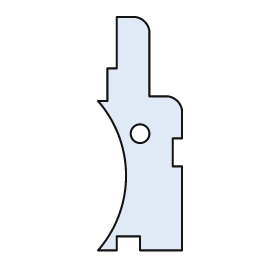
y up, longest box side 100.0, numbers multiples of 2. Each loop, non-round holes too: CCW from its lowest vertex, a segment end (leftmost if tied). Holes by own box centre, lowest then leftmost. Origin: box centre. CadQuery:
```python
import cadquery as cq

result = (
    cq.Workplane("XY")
    .moveTo(-18.0, -50.0)
    .lineTo(-10.0, -50.0)
    .lineTo(-10.0, -44.0)
    .lineTo(0.0, -44.0)
    .lineTo(0.0, -50.0)
    .lineTo(18.0, -50.0)
    .lineTo(18.0, -14.0)
    .lineTo(14.0, -14.0)
    .lineTo(14.0, -2.0)
    .lineTo(18.0, -2.0)
    .lineTo(18.0, 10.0)
    .threePointArc((16.0, 14.0), (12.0, 16.0))
    .lineTo(4.0, 16.0)
    .lineTo(4.0, 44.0)
    .threePointArc((2.0, 48.0), (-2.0, 50.0))
    .lineTo(-10.0, 50.0)
    .lineTo(-10.0, 28.0)
    .lineTo(-14.0, 28.0)
    .lineTo(-14.0, 14.0)
    .lineTo(-18.0, 14.0)
    .threePointArc((-6.0, -18.0), (-18.0, -50.0))
    .close()
    .moveTo(0.0, 0.0)
    .circle(4.0)
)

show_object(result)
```